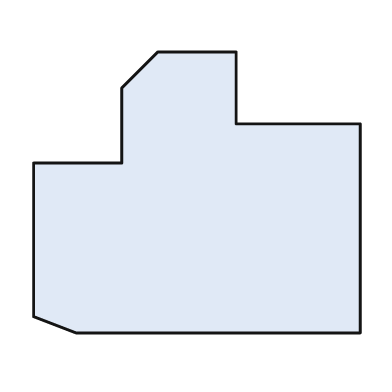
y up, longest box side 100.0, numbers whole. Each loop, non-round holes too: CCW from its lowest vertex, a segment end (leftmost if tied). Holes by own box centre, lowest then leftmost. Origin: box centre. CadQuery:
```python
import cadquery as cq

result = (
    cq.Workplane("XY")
    .moveTo(-37.0, -43.0)
    .lineTo(50.0, -43.0)
    .lineTo(50.0, 21.0)
    .lineTo(12.0, 21.0)
    .lineTo(12.0, 43.0)
    .lineTo(-12.0, 43.0)
    .lineTo(-23.0, 32.0)
    .lineTo(-23.0, 9.0)
    .lineTo(-50.0, 9.0)
    .lineTo(-50.0, -38.0)
    .close()
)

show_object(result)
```